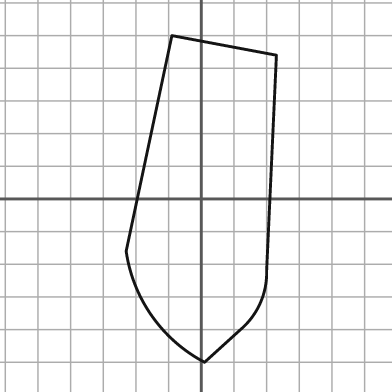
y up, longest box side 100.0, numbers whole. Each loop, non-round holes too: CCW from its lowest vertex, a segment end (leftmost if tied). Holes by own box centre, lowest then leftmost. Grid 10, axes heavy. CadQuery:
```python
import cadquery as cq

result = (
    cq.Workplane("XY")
    .moveTo(1.0, -50.0)
    .lineTo(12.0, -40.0)
    .threePointArc((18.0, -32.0), (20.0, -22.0))
    .lineTo(23.0, 44.0)
    .lineTo(-9.0, 50.0)
    .lineTo(-23.0, -16.0)
    .threePointArc((-15.0, -36.0), (1.0, -50.0))
    .close()
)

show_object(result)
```